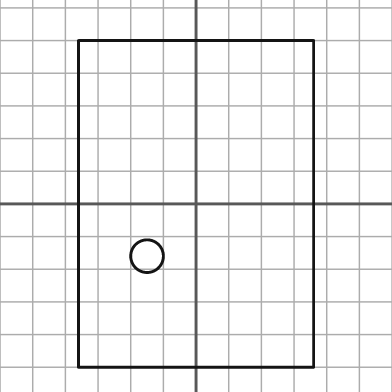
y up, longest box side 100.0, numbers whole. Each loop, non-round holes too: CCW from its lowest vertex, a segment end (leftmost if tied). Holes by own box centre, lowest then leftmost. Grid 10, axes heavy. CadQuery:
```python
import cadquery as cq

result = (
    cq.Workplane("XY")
    .moveTo(-36.0, -50.0)
    .lineTo(36.0, -50.0)
    .lineTo(36.0, 50.0)
    .lineTo(-36.0, 50.0)
    .close()
    .moveTo(-15.0, -16.0)
    .circle(5.0)
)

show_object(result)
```